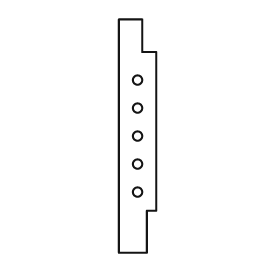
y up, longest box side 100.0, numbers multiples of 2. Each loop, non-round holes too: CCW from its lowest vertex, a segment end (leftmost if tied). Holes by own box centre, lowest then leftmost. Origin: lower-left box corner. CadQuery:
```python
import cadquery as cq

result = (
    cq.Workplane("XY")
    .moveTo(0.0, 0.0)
    .lineTo(12.0, 0.0)
    .lineTo(12.0, 18.0)
    .lineTo(16.0, 18.0)
    .lineTo(16.0, 86.0)
    .lineTo(10.0, 86.0)
    .lineTo(10.0, 100.0)
    .lineTo(0.0, 100.0)
    .close()
    .moveTo(8.0, 26.0)
    .circle(2.0)
    .moveTo(8.0, 38.0)
    .circle(2.0)
    .moveTo(8.0, 50.0)
    .circle(2.0)
    .moveTo(8.0, 62.0)
    .circle(2.0)
    .moveTo(8.0, 74.0)
    .circle(2.0)
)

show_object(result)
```